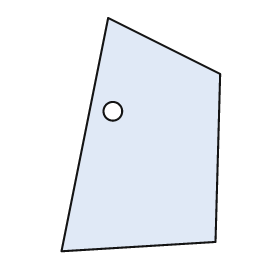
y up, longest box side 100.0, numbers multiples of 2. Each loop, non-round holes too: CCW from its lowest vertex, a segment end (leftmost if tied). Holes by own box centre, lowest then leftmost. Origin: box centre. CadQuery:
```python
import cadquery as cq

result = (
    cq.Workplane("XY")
    .moveTo(-34.0, -50.0)
    .lineTo(32.0, -46.0)
    .lineTo(34.0, 26.0)
    .lineTo(-14.0, 50.0)
    .close()
    .moveTo(-12.0, 10.0)
    .circle(4.0)
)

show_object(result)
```